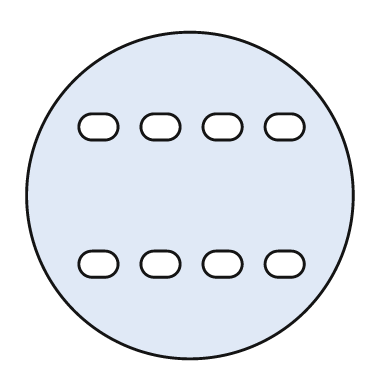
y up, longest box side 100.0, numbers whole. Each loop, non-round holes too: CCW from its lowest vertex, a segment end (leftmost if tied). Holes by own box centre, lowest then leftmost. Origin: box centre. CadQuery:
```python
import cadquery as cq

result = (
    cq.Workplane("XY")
    .moveTo(0.0, 0.0)
    .circle(50.0)
    .moveTo(-30.0, -25.0)
    .lineTo(-26.0, -25.0)
    .threePointArc((-22.0, -21.0), (-26.0, -17.0))
    .lineTo(-30.0, -17.0)
    .threePointArc((-34.0, -21.0), (-30.0, -25.0))
    .close()
    .moveTo(-11.0, -25.0)
    .lineTo(-7.0, -25.0)
    .threePointArc((-3.0, -21.0), (-7.0, -17.0))
    .lineTo(-11.0, -17.0)
    .threePointArc((-15.0, -21.0), (-11.0, -25.0))
    .close()
    .moveTo(8.0, -25.0)
    .lineTo(12.0, -25.0)
    .threePointArc((16.0, -21.0), (12.0, -17.0))
    .lineTo(8.0, -17.0)
    .threePointArc((4.0, -21.0), (8.0, -25.0))
    .close()
    .moveTo(27.0, -25.0)
    .lineTo(31.0, -25.0)
    .threePointArc((35.0, -21.0), (31.0, -17.0))
    .lineTo(27.0, -17.0)
    .threePointArc((23.0, -21.0), (27.0, -25.0))
    .close()
    .moveTo(-30.0, 17.0)
    .lineTo(-26.0, 17.0)
    .threePointArc((-22.0, 21.0), (-26.0, 25.0))
    .lineTo(-30.0, 25.0)
    .threePointArc((-34.0, 21.0), (-30.0, 17.0))
    .close()
    .moveTo(-11.0, 17.0)
    .lineTo(-7.0, 17.0)
    .threePointArc((-3.0, 21.0), (-7.0, 25.0))
    .lineTo(-11.0, 25.0)
    .threePointArc((-15.0, 21.0), (-11.0, 17.0))
    .close()
    .moveTo(8.0, 17.0)
    .lineTo(12.0, 17.0)
    .threePointArc((16.0, 21.0), (12.0, 25.0))
    .lineTo(8.0, 25.0)
    .threePointArc((4.0, 21.0), (8.0, 17.0))
    .close()
    .moveTo(27.0, 17.0)
    .lineTo(31.0, 17.0)
    .threePointArc((35.0, 21.0), (31.0, 25.0))
    .lineTo(27.0, 25.0)
    .threePointArc((23.0, 21.0), (27.0, 17.0))
    .close()
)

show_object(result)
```